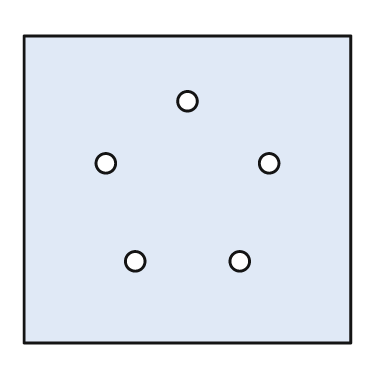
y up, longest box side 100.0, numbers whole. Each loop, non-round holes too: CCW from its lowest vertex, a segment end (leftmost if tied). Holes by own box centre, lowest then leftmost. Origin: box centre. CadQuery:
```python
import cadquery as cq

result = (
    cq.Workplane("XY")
    .moveTo(-50.0, -47.0)
    .lineTo(50.0, -47.0)
    .lineTo(50.0, 47.0)
    .lineTo(-50.0, 47.0)
    .close()
    .moveTo(-16.0, -22.0)
    .circle(3.0)
    .moveTo(16.0, -22.0)
    .circle(3.0)
    .moveTo(-25.0, 8.0)
    .circle(3.0)
    .moveTo(25.0, 8.0)
    .circle(3.0)
    .moveTo(0.0, 27.0)
    .circle(3.0)
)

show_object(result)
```